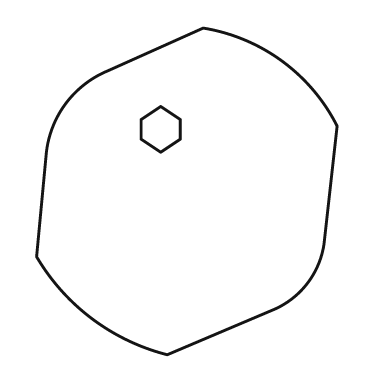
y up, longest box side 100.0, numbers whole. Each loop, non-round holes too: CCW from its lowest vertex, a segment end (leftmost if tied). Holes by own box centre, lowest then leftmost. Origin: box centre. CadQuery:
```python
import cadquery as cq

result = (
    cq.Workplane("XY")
    .moveTo(-6.0, -50.0)
    .lineTo(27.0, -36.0)
    .threePointArc((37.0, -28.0), (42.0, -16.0))
    .lineTo(46.0, 20.0)
    .threePointArc((29.0, 40.0), (5.0, 50.0))
    .lineTo(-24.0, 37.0)
    .threePointArc((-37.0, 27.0), (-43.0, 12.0))
    .lineTo(-46.0, -20.0)
    .threePointArc((-29.0, -39.0), (-6.0, -50.0))
    .close()
    .moveTo(-8.0, 12.0)
    .lineTo(-2.0, 16.0)
    .lineTo(-2.0, 22.0)
    .lineTo(-8.0, 26.0)
    .lineTo(-14.0, 22.0)
    .lineTo(-14.0, 16.0)
    .close()
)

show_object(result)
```